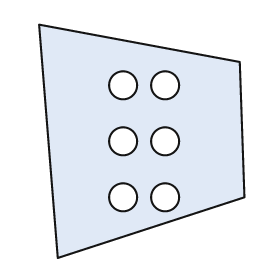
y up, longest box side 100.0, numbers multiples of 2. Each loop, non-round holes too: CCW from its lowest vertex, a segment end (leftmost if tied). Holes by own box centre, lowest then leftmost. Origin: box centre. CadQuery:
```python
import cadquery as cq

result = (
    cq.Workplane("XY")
    .moveTo(-36.0, -50.0)
    .lineTo(44.0, -24.0)
    .lineTo(42.0, 34.0)
    .lineTo(-44.0, 50.0)
    .close()
    .moveTo(-8.0, -24.0)
    .circle(6.0)
    .moveTo(10.0, -24.0)
    .circle(6.0)
    .moveTo(-8.0, 0.0)
    .circle(6.0)
    .moveTo(10.0, 0.0)
    .circle(6.0)
    .moveTo(-8.0, 24.0)
    .circle(6.0)
    .moveTo(10.0, 24.0)
    .circle(6.0)
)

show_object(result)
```